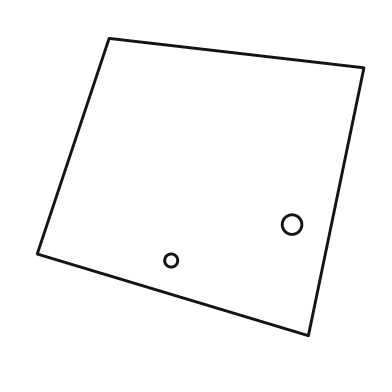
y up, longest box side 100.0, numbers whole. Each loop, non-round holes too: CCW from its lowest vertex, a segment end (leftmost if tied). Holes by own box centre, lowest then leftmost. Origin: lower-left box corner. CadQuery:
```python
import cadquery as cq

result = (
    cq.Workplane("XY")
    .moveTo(83.0, 0.0)
    .lineTo(100.0, 82.0)
    .lineTo(22.0, 91.0)
    .lineTo(0.0, 25.0)
    .close()
    .moveTo(41.0, 23.0)
    .circle(2.0)
    .moveTo(78.0, 34.0)
    .circle(3.0)
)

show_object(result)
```